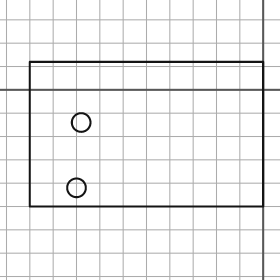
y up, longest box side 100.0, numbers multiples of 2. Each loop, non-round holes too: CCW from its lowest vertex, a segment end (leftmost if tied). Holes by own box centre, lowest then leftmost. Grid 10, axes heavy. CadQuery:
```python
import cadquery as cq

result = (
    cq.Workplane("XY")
    .moveTo(-100.0, -50.0)
    .lineTo(0.0, -50.0)
    .lineTo(0.0, 12.0)
    .lineTo(-100.0, 12.0)
    .close()
    .moveTo(-80.0, -42.0)
    .circle(4.0)
    .moveTo(-78.0, -14.0)
    .circle(4.0)
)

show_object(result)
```